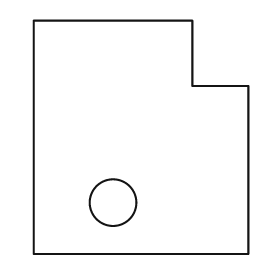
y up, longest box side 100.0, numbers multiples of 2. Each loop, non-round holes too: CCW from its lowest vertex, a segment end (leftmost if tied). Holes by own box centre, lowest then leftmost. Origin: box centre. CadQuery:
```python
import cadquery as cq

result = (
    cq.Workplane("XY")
    .moveTo(-46.0, -50.0)
    .lineTo(46.0, -50.0)
    .lineTo(46.0, 22.0)
    .lineTo(22.0, 22.0)
    .lineTo(22.0, 50.0)
    .lineTo(-46.0, 50.0)
    .close()
    .moveTo(-12.0, -28.0)
    .circle(10.0)
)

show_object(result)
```